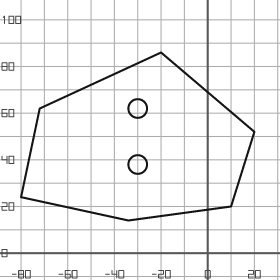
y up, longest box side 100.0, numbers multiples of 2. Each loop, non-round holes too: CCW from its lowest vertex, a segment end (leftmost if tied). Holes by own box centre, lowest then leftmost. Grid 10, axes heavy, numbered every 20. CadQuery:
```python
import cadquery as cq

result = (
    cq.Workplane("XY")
    .moveTo(-34.0, 14.0)
    .lineTo(10.0, 20.0)
    .lineTo(20.0, 52.0)
    .lineTo(-20.0, 86.0)
    .lineTo(-72.0, 62.0)
    .lineTo(-80.0, 24.0)
    .close()
    .moveTo(-30.0, 38.0)
    .circle(4.0)
    .moveTo(-30.0, 62.0)
    .circle(4.0)
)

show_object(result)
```